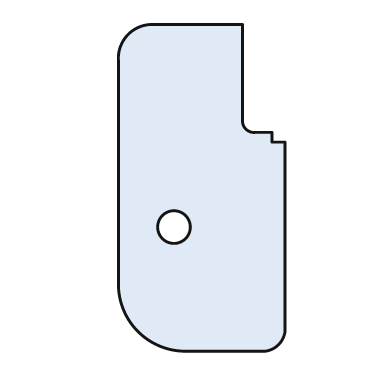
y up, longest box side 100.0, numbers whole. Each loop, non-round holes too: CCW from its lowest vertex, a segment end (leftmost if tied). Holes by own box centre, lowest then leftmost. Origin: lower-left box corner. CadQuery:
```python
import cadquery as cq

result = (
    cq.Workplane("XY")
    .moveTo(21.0, 0.0)
    .lineTo(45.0, 0.0)
    .threePointArc((49.0, 2.0), (51.0, 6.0))
    .lineTo(51.0, 64.0)
    .lineTo(47.0, 64.0)
    .lineTo(47.0, 67.0)
    .lineTo(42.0, 67.0)
    .threePointArc((39.0, 68.0), (38.0, 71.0))
    .lineTo(38.0, 100.0)
    .lineTo(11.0, 100.0)
    .threePointArc((3.0, 97.0), (0.0, 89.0))
    .lineTo(0.0, 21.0)
    .threePointArc((6.0, 6.0), (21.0, 0.0))
    .close()
    .moveTo(17.0, 38.0)
    .circle(5.0)
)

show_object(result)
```